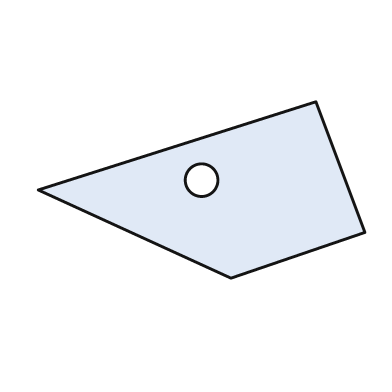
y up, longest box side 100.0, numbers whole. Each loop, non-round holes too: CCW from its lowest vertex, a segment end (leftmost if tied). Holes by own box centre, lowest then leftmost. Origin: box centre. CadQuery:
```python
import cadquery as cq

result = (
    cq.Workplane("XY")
    .moveTo(9.0, -27.0)
    .lineTo(50.0, -13.0)
    .lineTo(35.0, 27.0)
    .lineTo(-50.0, 0.0)
    .close()
    .moveTo(0.0, 3.0)
    .circle(5.0)
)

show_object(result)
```